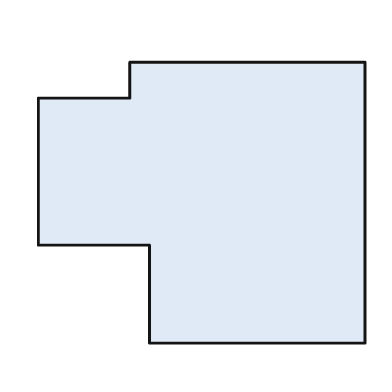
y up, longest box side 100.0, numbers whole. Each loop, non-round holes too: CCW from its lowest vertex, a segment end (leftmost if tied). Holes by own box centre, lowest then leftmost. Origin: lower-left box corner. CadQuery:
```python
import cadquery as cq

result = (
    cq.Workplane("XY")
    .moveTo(34.0, 0.0)
    .lineTo(100.0, 0.0)
    .lineTo(100.0, 86.0)
    .lineTo(28.0, 86.0)
    .lineTo(28.0, 75.0)
    .lineTo(0.0, 75.0)
    .lineTo(0.0, 30.0)
    .lineTo(34.0, 30.0)
    .close()
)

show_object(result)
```